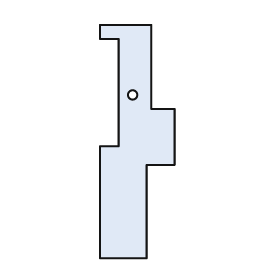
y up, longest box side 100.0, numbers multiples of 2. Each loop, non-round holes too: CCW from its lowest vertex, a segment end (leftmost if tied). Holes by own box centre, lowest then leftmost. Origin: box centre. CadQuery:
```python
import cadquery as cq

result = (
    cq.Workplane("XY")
    .moveTo(-16.0, -50.0)
    .lineTo(4.0, -50.0)
    .lineTo(4.0, -10.0)
    .lineTo(16.0, -10.0)
    .lineTo(16.0, 14.0)
    .lineTo(6.0, 14.0)
    .lineTo(6.0, 50.0)
    .lineTo(-16.0, 50.0)
    .lineTo(-16.0, 44.0)
    .lineTo(-8.0, 44.0)
    .lineTo(-8.0, -2.0)
    .lineTo(-16.0, -2.0)
    .close()
    .moveTo(-2.0, 20.0)
    .circle(2.0)
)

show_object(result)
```